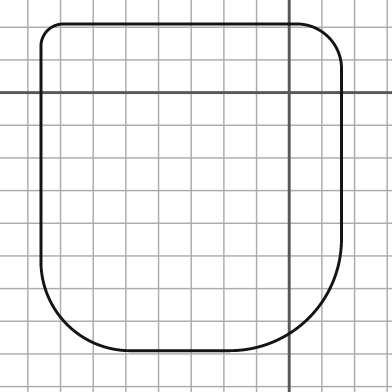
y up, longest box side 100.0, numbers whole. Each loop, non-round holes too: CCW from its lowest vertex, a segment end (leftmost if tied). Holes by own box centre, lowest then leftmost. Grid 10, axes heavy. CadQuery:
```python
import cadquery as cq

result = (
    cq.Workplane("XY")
    .moveTo(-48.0, -79.0)
    .lineTo(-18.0, -79.0)
    .threePointArc((6.0, -69.0), (16.0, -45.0))
    .lineTo(16.0, 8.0)
    .threePointArc((12.0, 17.0), (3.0, 21.0))
    .lineTo(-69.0, 21.0)
    .threePointArc((-74.0, 19.0), (-76.0, 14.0))
    .lineTo(-76.0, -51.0)
    .threePointArc((-68.0, -71.0), (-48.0, -79.0))
    .close()
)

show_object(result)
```